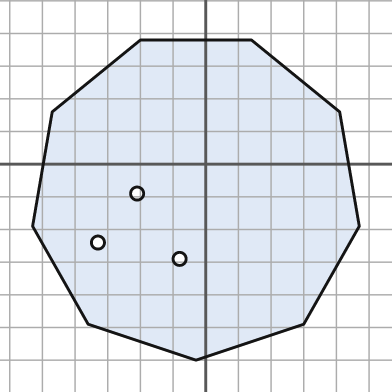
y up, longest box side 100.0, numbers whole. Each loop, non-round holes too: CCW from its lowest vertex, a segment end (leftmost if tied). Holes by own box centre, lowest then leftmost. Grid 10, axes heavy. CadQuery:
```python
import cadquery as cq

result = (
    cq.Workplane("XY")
    .moveTo(-3.0, -60.0)
    .lineTo(30.0, -49.0)
    .lineTo(47.0, -19.0)
    .lineTo(41.0, 16.0)
    .lineTo(14.0, 38.0)
    .lineTo(-20.0, 38.0)
    .lineTo(-47.0, 16.0)
    .lineTo(-53.0, -19.0)
    .lineTo(-36.0, -49.0)
    .close()
    .moveTo(-8.0, -29.0)
    .circle(2.0)
    .moveTo(-33.0, -24.0)
    .circle(2.0)
    .moveTo(-21.0, -9.0)
    .circle(2.0)
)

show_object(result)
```